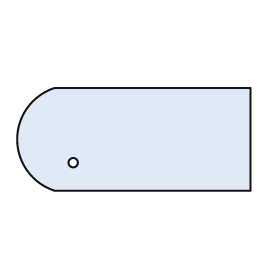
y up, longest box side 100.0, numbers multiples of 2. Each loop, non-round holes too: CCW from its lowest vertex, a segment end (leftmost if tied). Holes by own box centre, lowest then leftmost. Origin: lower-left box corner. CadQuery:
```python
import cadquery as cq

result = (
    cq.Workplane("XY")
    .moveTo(16.0, 0.0)
    .lineTo(100.0, 0.0)
    .lineTo(100.0, 44.0)
    .lineTo(16.0, 44.0)
    .threePointArc((0.0, 22.0), (16.0, 0.0))
    .close()
    .moveTo(24.0, 12.0)
    .circle(2.0)
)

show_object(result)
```